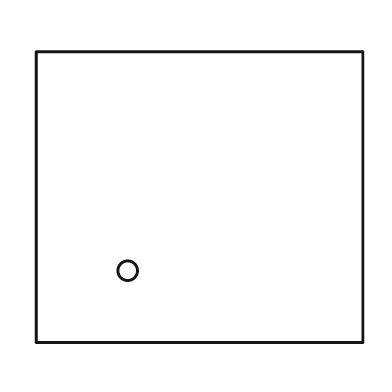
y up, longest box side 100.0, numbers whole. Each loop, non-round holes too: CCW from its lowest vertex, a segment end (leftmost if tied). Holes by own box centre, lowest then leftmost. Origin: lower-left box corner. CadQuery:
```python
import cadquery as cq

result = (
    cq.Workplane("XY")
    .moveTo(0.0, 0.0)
    .lineTo(100.0, 0.0)
    .lineTo(100.0, 89.0)
    .lineTo(0.0, 89.0)
    .close()
    .moveTo(28.0, 22.0)
    .circle(3.0)
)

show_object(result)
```